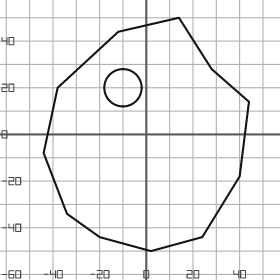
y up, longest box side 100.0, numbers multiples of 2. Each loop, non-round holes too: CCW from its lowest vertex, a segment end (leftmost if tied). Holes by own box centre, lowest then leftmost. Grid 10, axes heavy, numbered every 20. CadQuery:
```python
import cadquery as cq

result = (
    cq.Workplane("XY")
    .moveTo(2.0, -50.0)
    .lineTo(24.0, -44.0)
    .lineTo(40.0, -18.0)
    .lineTo(44.0, 14.0)
    .lineTo(28.0, 28.0)
    .lineTo(14.0, 50.0)
    .lineTo(-12.0, 44.0)
    .lineTo(-38.0, 20.0)
    .lineTo(-44.0, -8.0)
    .lineTo(-34.0, -34.0)
    .lineTo(-20.0, -44.0)
    .close()
    .moveTo(-10.0, 20.0)
    .circle(8.0)
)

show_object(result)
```